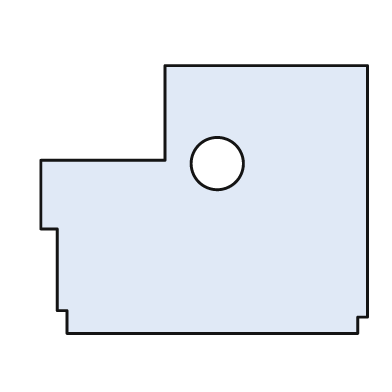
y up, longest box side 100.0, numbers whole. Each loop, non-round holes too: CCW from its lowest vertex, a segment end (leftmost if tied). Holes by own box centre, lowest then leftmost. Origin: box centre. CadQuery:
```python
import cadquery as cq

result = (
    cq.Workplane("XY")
    .moveTo(-42.0, -41.0)
    .lineTo(47.0, -41.0)
    .lineTo(47.0, -36.0)
    .lineTo(50.0, -36.0)
    .lineTo(50.0, 41.0)
    .lineTo(-12.0, 41.0)
    .lineTo(-12.0, 12.0)
    .lineTo(-50.0, 12.0)
    .lineTo(-50.0, -9.0)
    .lineTo(-45.0, -9.0)
    .lineTo(-45.0, -34.0)
    .lineTo(-42.0, -34.0)
    .close()
    .moveTo(4.0, 11.0)
    .circle(8.0)
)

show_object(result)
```